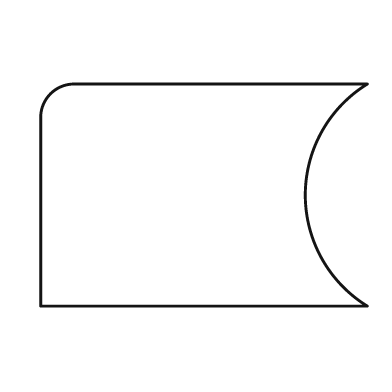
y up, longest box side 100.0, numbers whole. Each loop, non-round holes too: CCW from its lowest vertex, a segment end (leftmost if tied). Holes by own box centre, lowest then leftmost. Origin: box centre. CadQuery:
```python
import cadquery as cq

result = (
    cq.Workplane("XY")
    .moveTo(-50.0, -34.0)
    .lineTo(50.0, -34.0)
    .threePointArc((31.0, 0.0), (50.0, 34.0))
    .lineTo(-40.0, 34.0)
    .threePointArc((-47.0, 31.0), (-50.0, 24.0))
    .close()
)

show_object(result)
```